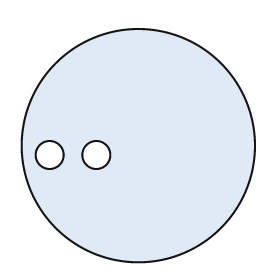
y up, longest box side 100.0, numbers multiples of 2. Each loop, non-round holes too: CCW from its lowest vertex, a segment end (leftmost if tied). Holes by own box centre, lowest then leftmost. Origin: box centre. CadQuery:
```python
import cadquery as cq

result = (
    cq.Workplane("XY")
    .moveTo(0.0, 0.0)
    .circle(50.0)
    .moveTo(-38.0, -4.0)
    .circle(6.0)
    .moveTo(-18.0, -4.0)
    .circle(6.0)
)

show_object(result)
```